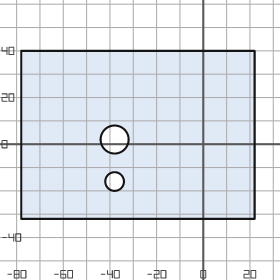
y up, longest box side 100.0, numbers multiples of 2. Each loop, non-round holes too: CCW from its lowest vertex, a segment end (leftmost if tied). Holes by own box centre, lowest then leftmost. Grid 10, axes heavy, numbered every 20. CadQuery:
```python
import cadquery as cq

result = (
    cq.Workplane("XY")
    .moveTo(-78.0, -32.0)
    .lineTo(22.0, -32.0)
    .lineTo(22.0, 40.0)
    .lineTo(-78.0, 40.0)
    .close()
    .moveTo(-38.0, -16.0)
    .circle(4.0)
    .moveTo(-38.0, 2.0)
    .circle(6.0)
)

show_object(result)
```